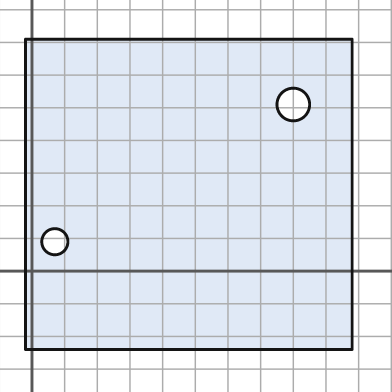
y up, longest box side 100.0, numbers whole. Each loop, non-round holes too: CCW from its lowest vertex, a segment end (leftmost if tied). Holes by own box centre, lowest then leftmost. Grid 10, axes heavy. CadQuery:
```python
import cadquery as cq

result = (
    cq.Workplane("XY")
    .moveTo(-2.0, -24.0)
    .lineTo(98.0, -24.0)
    .lineTo(98.0, 71.0)
    .lineTo(-2.0, 71.0)
    .close()
    .moveTo(7.0, 9.0)
    .circle(4.0)
    .moveTo(80.0, 51.0)
    .circle(5.0)
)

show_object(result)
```